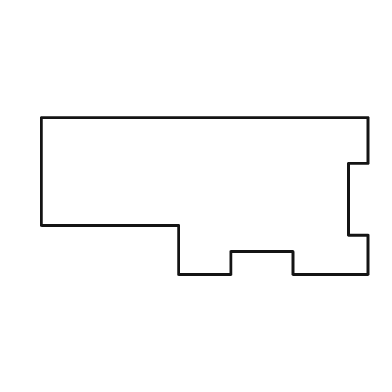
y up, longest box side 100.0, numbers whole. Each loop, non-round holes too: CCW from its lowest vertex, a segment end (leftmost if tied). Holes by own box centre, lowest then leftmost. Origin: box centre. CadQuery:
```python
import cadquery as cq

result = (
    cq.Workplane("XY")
    .moveTo(-8.0, -24.0)
    .lineTo(8.0, -24.0)
    .lineTo(8.0, -17.0)
    .lineTo(27.0, -17.0)
    .lineTo(27.0, -24.0)
    .lineTo(50.0, -24.0)
    .lineTo(50.0, -12.0)
    .lineTo(44.0, -12.0)
    .lineTo(44.0, 10.0)
    .lineTo(50.0, 10.0)
    .lineTo(50.0, 24.0)
    .lineTo(-50.0, 24.0)
    .lineTo(-50.0, -9.0)
    .lineTo(-8.0, -9.0)
    .close()
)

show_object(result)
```